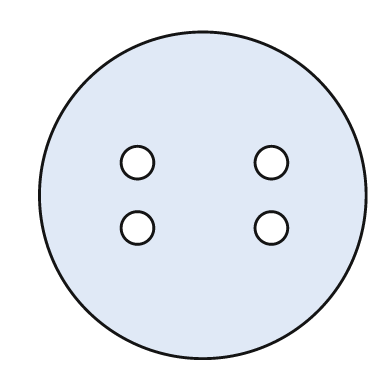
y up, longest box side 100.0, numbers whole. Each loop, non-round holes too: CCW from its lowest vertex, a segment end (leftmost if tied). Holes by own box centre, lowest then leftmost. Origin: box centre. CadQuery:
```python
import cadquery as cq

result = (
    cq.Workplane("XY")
    .moveTo(0.0, 0.0)
    .circle(50.0)
    .moveTo(-20.0, -10.0)
    .circle(5.0)
    .moveTo(21.0, -10.0)
    .circle(5.0)
    .moveTo(-20.0, 10.0)
    .circle(5.0)
    .moveTo(21.0, 10.0)
    .circle(5.0)
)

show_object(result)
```